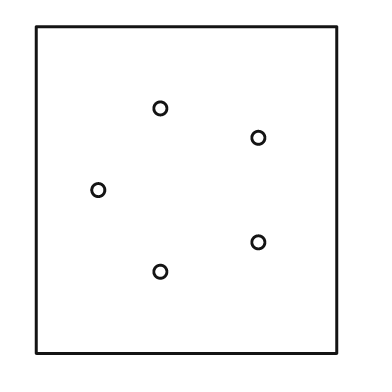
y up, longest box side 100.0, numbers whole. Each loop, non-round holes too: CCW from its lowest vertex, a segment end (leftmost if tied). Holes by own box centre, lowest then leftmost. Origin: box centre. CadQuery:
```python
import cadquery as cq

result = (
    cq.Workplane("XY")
    .moveTo(-46.0, -50.0)
    .lineTo(46.0, -50.0)
    .lineTo(46.0, 50.0)
    .lineTo(-46.0, 50.0)
    .close()
    .moveTo(-8.0, -25.0)
    .circle(2.0)
    .moveTo(22.0, -16.0)
    .circle(2.0)
    .moveTo(-27.0, 0.0)
    .circle(2.0)
    .moveTo(22.0, 16.0)
    .circle(2.0)
    .moveTo(-8.0, 25.0)
    .circle(2.0)
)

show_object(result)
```